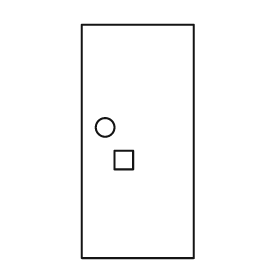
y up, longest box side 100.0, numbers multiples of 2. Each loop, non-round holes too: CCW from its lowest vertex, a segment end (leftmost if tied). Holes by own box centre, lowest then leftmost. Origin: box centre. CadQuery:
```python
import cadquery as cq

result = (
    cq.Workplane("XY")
    .moveTo(-24.0, -50.0)
    .lineTo(24.0, -50.0)
    .lineTo(24.0, 50.0)
    .lineTo(-24.0, 50.0)
    .close()
    .moveTo(-10.0, -12.0)
    .lineTo(-2.0, -12.0)
    .lineTo(-2.0, -4.0)
    .lineTo(-10.0, -4.0)
    .close()
    .moveTo(-14.0, 6.0)
    .circle(4.0)
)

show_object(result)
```